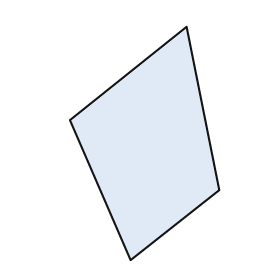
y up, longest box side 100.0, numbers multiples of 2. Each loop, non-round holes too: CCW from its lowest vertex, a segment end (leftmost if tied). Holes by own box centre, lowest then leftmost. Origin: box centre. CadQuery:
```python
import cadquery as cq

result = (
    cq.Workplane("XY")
    .moveTo(-6.0, -50.0)
    .lineTo(32.0, -20.0)
    .lineTo(18.0, 50.0)
    .lineTo(-32.0, 10.0)
    .close()
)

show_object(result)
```